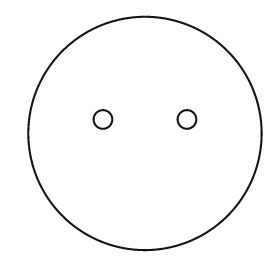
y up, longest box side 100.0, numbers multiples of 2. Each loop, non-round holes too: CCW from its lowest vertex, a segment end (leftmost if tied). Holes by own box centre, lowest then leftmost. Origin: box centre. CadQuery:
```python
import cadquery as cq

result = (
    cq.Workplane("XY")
    .moveTo(0.0, 0.0)
    .circle(50.0)
    .moveTo(-18.0, 6.0)
    .circle(4.0)
    .moveTo(18.0, 6.0)
    .circle(4.0)
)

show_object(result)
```